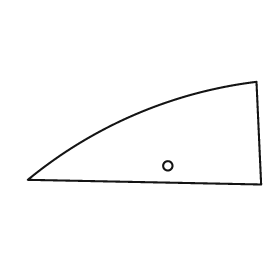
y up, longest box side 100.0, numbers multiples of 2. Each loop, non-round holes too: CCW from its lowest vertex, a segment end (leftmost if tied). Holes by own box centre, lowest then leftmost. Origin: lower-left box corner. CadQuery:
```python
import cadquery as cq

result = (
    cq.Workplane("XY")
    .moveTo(100.0, 0.0)
    .lineTo(98.0, 44.0)
    .threePointArc((46.0, 30.0), (0.0, 2.0))
    .close()
    .moveTo(60.0, 8.0)
    .circle(2.0)
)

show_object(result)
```